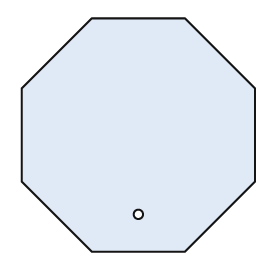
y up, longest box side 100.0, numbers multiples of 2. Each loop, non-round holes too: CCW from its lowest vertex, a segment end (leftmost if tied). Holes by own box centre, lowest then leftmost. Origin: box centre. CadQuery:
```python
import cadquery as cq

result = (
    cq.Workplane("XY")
    .moveTo(-20.0, -50.0)
    .lineTo(20.0, -50.0)
    .lineTo(50.0, -20.0)
    .lineTo(50.0, 20.0)
    .lineTo(20.0, 50.0)
    .lineTo(-20.0, 50.0)
    .lineTo(-50.0, 20.0)
    .lineTo(-50.0, -20.0)
    .close()
    .moveTo(0.0, -34.0)
    .circle(2.0)
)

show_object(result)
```